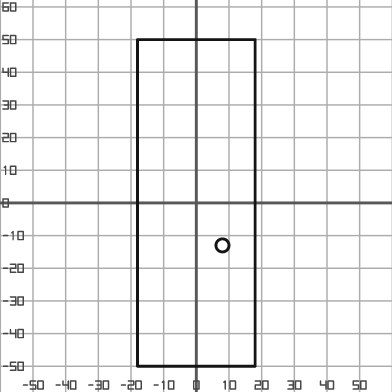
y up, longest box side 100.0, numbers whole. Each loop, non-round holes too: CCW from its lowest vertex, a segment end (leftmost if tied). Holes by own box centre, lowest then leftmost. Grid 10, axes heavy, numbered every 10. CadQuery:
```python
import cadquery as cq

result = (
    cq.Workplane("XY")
    .moveTo(-18.0, -50.0)
    .lineTo(18.0, -50.0)
    .lineTo(18.0, 50.0)
    .lineTo(-18.0, 50.0)
    .close()
    .moveTo(8.0, -13.0)
    .circle(2.0)
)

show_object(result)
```